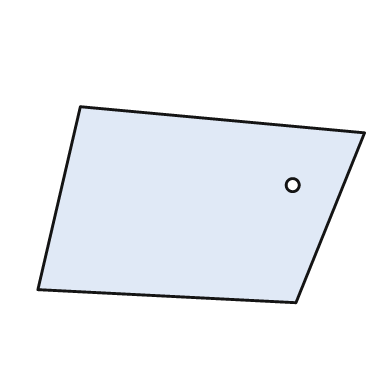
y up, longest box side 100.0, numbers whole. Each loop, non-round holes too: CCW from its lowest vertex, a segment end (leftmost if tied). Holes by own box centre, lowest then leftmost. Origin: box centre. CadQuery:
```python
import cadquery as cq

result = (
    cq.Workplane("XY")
    .moveTo(29.0, -30.0)
    .lineTo(50.0, 22.0)
    .lineTo(-37.0, 30.0)
    .lineTo(-50.0, -26.0)
    .close()
    .moveTo(28.0, 6.0)
    .circle(2.0)
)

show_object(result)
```